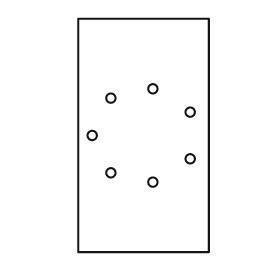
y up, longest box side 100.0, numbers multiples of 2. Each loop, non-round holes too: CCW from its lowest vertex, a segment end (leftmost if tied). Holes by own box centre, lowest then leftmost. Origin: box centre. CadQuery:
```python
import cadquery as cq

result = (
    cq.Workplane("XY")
    .moveTo(-28.0, -50.0)
    .lineTo(28.0, -50.0)
    .lineTo(28.0, 50.0)
    .lineTo(-28.0, 50.0)
    .close()
    .moveTo(4.0, -20.0)
    .circle(2.0)
    .moveTo(-14.0, -16.0)
    .circle(2.0)
    .moveTo(20.0, -10.0)
    .circle(2.0)
    .moveTo(-22.0, 0.0)
    .circle(2.0)
    .moveTo(20.0, 10.0)
    .circle(2.0)
    .moveTo(-14.0, 16.0)
    .circle(2.0)
    .moveTo(4.0, 20.0)
    .circle(2.0)
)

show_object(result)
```